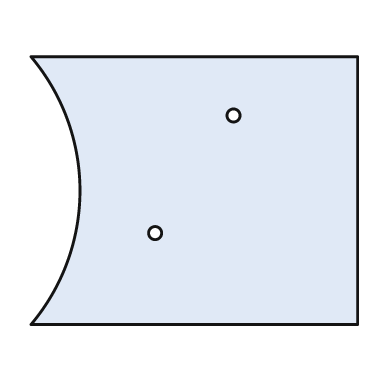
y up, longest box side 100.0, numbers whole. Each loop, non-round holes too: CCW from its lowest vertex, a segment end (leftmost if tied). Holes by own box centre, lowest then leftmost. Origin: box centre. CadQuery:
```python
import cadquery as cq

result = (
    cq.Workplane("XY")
    .moveTo(-50.0, -41.0)
    .lineTo(50.0, -41.0)
    .lineTo(50.0, 41.0)
    .lineTo(-50.0, 41.0)
    .threePointArc((-35.0, 0.0), (-50.0, -41.0))
    .close()
    .moveTo(-12.0, -13.0)
    .circle(2.0)
    .moveTo(12.0, 23.0)
    .circle(2.0)
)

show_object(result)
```